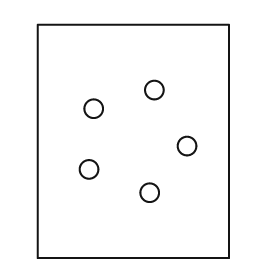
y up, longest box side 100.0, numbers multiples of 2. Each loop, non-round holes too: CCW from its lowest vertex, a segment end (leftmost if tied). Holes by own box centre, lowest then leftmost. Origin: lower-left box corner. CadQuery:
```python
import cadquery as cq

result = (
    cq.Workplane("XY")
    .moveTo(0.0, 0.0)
    .lineTo(82.0, 0.0)
    .lineTo(82.0, 100.0)
    .lineTo(0.0, 100.0)
    .close()
    .moveTo(48.0, 28.0)
    .circle(4.0)
    .moveTo(22.0, 38.0)
    .circle(4.0)
    .moveTo(64.0, 48.0)
    .circle(4.0)
    .moveTo(24.0, 64.0)
    .circle(4.0)
    .moveTo(50.0, 72.0)
    .circle(4.0)
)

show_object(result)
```